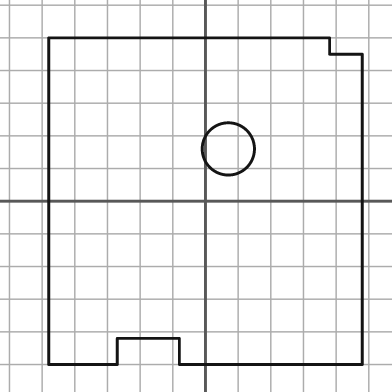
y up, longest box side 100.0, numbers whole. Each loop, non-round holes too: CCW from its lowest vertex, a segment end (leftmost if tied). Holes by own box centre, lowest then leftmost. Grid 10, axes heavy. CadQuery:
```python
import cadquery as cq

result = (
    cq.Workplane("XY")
    .moveTo(-48.0, -50.0)
    .lineTo(-27.0, -50.0)
    .lineTo(-27.0, -42.0)
    .lineTo(-8.0, -42.0)
    .lineTo(-8.0, -50.0)
    .lineTo(48.0, -50.0)
    .lineTo(48.0, 45.0)
    .lineTo(38.0, 45.0)
    .lineTo(38.0, 50.0)
    .lineTo(-48.0, 50.0)
    .close()
    .moveTo(7.0, 16.0)
    .circle(8.0)
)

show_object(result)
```